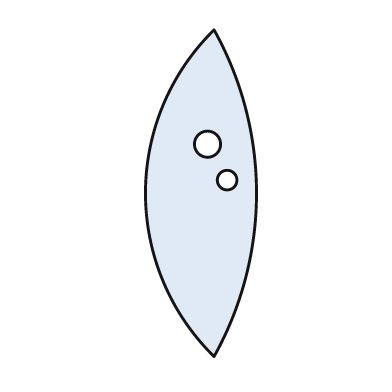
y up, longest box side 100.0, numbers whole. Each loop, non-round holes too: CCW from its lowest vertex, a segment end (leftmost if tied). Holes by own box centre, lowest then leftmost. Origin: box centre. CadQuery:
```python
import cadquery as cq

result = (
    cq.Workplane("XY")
    .moveTo(4.0, -50.0)
    .threePointArc((17.0, 0.0), (4.0, 50.0))
    .threePointArc((-17.0, 0.0), (4.0, -50.0))
    .close()
    .moveTo(8.0, 4.0)
    .circle(3.0)
    .moveTo(2.0, 15.0)
    .circle(4.0)
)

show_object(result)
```